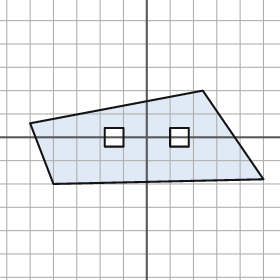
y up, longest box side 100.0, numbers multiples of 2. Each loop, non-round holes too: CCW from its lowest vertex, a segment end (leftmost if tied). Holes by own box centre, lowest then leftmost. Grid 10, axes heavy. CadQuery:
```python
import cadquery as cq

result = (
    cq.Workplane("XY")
    .moveTo(-40.0, -20.0)
    .lineTo(50.0, -18.0)
    .lineTo(24.0, 20.0)
    .lineTo(-50.0, 6.0)
    .close()
    .moveTo(-18.0, -4.0)
    .lineTo(-10.0, -4.0)
    .lineTo(-10.0, 4.0)
    .lineTo(-18.0, 4.0)
    .close()
    .moveTo(10.0, -4.0)
    .lineTo(18.0, -4.0)
    .lineTo(18.0, 4.0)
    .lineTo(10.0, 4.0)
    .close()
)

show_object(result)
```